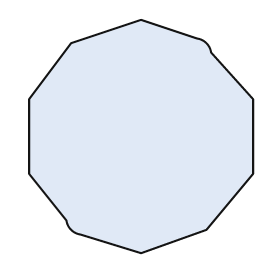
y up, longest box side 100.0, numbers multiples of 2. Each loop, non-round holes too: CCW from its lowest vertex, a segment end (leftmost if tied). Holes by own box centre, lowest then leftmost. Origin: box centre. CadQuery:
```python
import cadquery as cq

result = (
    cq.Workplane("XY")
    .moveTo(0.0, -50.0)
    .lineTo(28.0, -40.0)
    .lineTo(48.0, -16.0)
    .lineTo(48.0, 16.0)
    .lineTo(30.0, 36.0)
    .threePointArc((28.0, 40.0), (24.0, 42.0))
    .lineTo(0.0, 50.0)
    .lineTo(-30.0, 40.0)
    .lineTo(-48.0, 16.0)
    .lineTo(-48.0, -16.0)
    .lineTo(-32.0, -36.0)
    .threePointArc((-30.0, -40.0), (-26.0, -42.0))
    .close()
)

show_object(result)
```